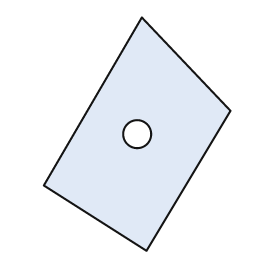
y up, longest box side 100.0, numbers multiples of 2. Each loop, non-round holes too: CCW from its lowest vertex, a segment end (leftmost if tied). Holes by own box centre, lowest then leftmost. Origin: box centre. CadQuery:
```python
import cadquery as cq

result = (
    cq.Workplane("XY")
    .moveTo(4.0, -50.0)
    .lineTo(40.0, 10.0)
    .lineTo(2.0, 50.0)
    .lineTo(-40.0, -22.0)
    .close()
    .moveTo(0.0, 0.0)
    .circle(6.0)
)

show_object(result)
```